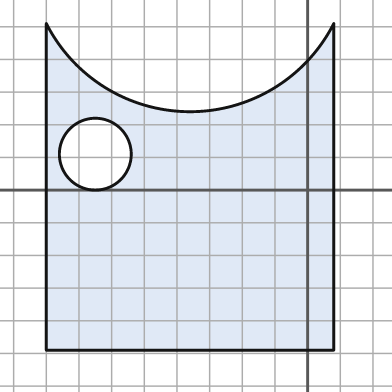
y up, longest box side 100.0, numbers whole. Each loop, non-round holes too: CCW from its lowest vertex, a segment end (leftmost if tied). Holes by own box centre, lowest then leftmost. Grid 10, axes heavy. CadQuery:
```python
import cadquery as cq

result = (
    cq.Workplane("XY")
    .moveTo(-80.0, -49.0)
    .lineTo(8.0, -49.0)
    .lineTo(8.0, 51.0)
    .threePointArc((-36.0, 24.0), (-80.0, 51.0))
    .close()
    .moveTo(-65.0, 11.0)
    .circle(11.0)
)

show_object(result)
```